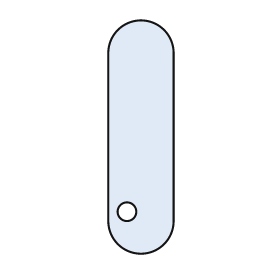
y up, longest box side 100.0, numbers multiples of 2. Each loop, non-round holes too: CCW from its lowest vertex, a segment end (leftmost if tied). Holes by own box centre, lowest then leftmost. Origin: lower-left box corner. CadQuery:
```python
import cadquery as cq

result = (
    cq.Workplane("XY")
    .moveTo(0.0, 14.0)
    .threePointArc((14.0, 0.0), (28.0, 14.0))
    .lineTo(28.0, 86.0)
    .threePointArc((14.0, 100.0), (0.0, 86.0))
    .close()
    .moveTo(8.0, 18.0)
    .circle(4.0)
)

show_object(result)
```